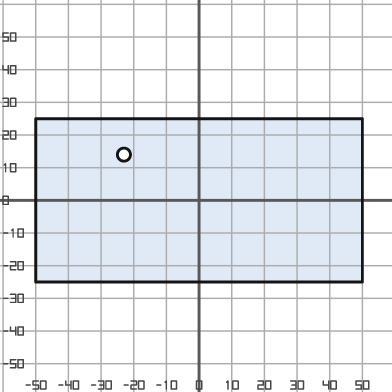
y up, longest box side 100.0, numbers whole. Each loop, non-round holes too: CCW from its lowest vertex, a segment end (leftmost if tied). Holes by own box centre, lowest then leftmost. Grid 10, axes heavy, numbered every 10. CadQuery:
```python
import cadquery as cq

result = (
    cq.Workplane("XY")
    .moveTo(-50.0, -25.0)
    .lineTo(50.0, -25.0)
    .lineTo(50.0, 25.0)
    .lineTo(-50.0, 25.0)
    .close()
    .moveTo(-23.0, 14.0)
    .circle(2.0)
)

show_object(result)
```